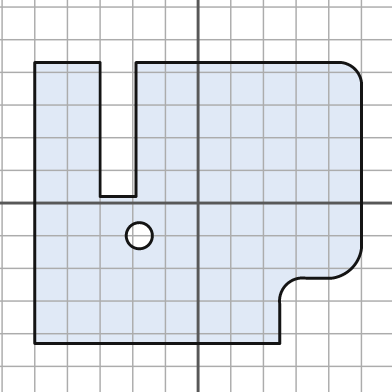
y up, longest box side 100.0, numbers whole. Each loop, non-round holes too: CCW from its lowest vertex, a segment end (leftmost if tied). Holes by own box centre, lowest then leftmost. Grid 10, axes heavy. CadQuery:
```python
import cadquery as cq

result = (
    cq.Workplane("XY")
    .moveTo(-50.0, -43.0)
    .lineTo(25.0, -43.0)
    .lineTo(25.0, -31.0)
    .threePointArc((27.0, -25.0), (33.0, -23.0))
    .lineTo(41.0, -23.0)
    .threePointArc((47.0, -20.0), (50.0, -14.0))
    .lineTo(50.0, 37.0)
    .threePointArc((48.0, 41.0), (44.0, 43.0))
    .lineTo(-19.0, 43.0)
    .lineTo(-19.0, 2.0)
    .lineTo(-30.0, 2.0)
    .lineTo(-30.0, 43.0)
    .lineTo(-50.0, 43.0)
    .close()
    .moveTo(-18.0, -10.0)
    .circle(4.0)
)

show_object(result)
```